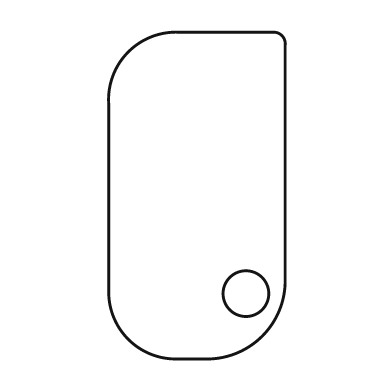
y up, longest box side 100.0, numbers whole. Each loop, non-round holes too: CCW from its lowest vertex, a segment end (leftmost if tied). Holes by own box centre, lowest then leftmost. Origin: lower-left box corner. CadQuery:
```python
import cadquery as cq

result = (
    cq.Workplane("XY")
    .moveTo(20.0, 0.0)
    .lineTo(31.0, 0.0)
    .threePointArc((47.0, 7.0), (54.0, 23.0))
    .lineTo(54.0, 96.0)
    .threePointArc((53.0, 99.0), (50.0, 100.0))
    .lineTo(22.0, 100.0)
    .threePointArc((6.0, 94.0), (0.0, 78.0))
    .lineTo(0.0, 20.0)
    .threePointArc((6.0, 6.0), (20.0, 0.0))
    .close()
    .moveTo(42.0, 20.0)
    .circle(7.0)
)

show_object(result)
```